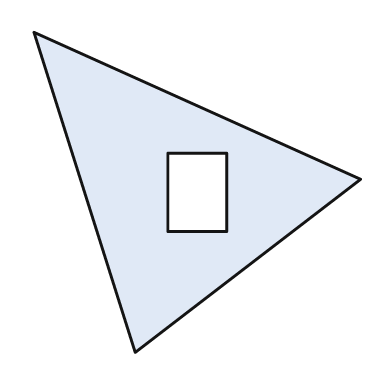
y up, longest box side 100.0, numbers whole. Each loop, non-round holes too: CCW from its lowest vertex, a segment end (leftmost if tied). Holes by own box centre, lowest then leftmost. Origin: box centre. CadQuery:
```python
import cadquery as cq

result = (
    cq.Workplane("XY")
    .moveTo(-19.0, -49.0)
    .lineTo(50.0, 4.0)
    .lineTo(-50.0, 49.0)
    .close()
    .moveTo(-9.0, -12.0)
    .lineTo(9.0, -12.0)
    .lineTo(9.0, 12.0)
    .lineTo(-9.0, 12.0)
    .close()
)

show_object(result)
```